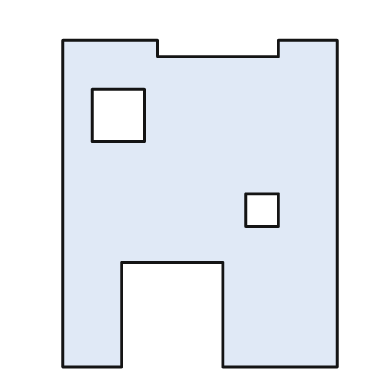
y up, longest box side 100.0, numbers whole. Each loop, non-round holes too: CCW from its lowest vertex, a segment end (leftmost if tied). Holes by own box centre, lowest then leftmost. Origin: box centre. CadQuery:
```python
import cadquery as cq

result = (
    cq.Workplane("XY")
    .moveTo(-42.0, -50.0)
    .lineTo(-24.0, -50.0)
    .lineTo(-24.0, -18.0)
    .lineTo(7.0, -18.0)
    .lineTo(7.0, -50.0)
    .lineTo(42.0, -50.0)
    .lineTo(42.0, 50.0)
    .lineTo(24.0, 50.0)
    .lineTo(24.0, 45.0)
    .lineTo(-13.0, 45.0)
    .lineTo(-13.0, 50.0)
    .lineTo(-42.0, 50.0)
    .close()
    .moveTo(14.0, -7.0)
    .lineTo(24.0, -7.0)
    .lineTo(24.0, 3.0)
    .lineTo(14.0, 3.0)
    .close()
    .moveTo(-33.0, 19.0)
    .lineTo(-17.0, 19.0)
    .lineTo(-17.0, 35.0)
    .lineTo(-33.0, 35.0)
    .close()
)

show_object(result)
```